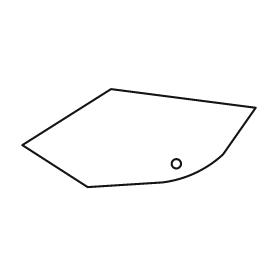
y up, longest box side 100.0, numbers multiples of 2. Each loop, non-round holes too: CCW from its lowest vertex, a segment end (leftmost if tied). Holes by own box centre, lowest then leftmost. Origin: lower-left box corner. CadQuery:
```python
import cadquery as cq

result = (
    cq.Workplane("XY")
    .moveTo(28.0, 0.0)
    .lineTo(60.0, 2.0)
    .threePointArc((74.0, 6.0), (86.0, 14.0))
    .lineTo(100.0, 34.0)
    .lineTo(38.0, 42.0)
    .lineTo(0.0, 18.0)
    .close()
    .moveTo(66.0, 10.0)
    .circle(2.0)
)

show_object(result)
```